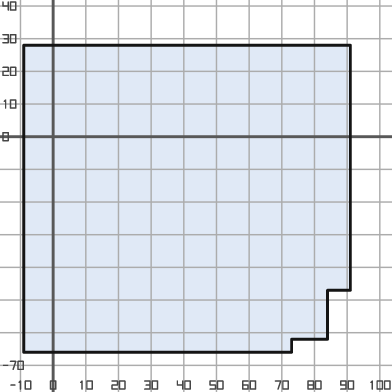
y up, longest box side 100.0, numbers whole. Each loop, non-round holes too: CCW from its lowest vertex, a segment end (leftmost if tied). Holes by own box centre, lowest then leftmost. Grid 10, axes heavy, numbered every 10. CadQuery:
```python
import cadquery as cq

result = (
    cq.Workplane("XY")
    .moveTo(-9.0, -66.0)
    .lineTo(73.0, -66.0)
    .lineTo(73.0, -62.0)
    .lineTo(84.0, -62.0)
    .lineTo(84.0, -47.0)
    .lineTo(91.0, -47.0)
    .lineTo(91.0, 28.0)
    .lineTo(-9.0, 28.0)
    .close()
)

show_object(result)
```